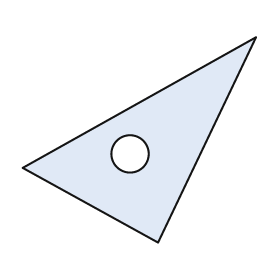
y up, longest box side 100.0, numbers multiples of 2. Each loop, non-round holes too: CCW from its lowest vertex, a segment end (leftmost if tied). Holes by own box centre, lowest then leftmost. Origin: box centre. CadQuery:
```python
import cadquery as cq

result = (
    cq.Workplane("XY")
    .moveTo(8.0, -44.0)
    .lineTo(50.0, 44.0)
    .lineTo(-50.0, -12.0)
    .close()
    .moveTo(-4.0, -6.0)
    .circle(8.0)
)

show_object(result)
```